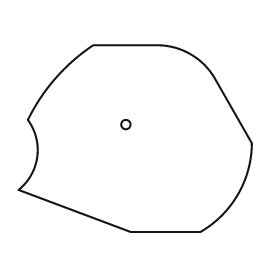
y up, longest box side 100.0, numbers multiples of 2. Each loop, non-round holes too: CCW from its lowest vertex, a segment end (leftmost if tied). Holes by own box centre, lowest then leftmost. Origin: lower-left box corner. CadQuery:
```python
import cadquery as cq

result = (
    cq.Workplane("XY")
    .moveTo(48.0, 0.0)
    .lineTo(78.0, 0.0)
    .threePointArc((94.0, 16.0), (100.0, 38.0))
    .lineTo(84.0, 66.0)
    .threePointArc((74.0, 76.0), (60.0, 80.0))
    .lineTo(32.0, 80.0)
    .threePointArc((16.0, 66.0), (4.0, 48.0))
    .threePointArc((8.0, 32.0), (0.0, 18.0))
    .close()
    .moveTo(46.0, 46.0)
    .circle(2.0)
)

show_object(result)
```